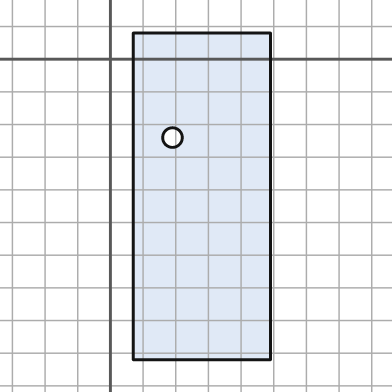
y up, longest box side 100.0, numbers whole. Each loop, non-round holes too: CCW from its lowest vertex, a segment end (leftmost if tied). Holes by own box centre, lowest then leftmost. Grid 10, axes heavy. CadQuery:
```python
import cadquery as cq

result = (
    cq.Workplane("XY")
    .moveTo(7.0, -92.0)
    .lineTo(49.0, -92.0)
    .lineTo(49.0, 8.0)
    .lineTo(7.0, 8.0)
    .close()
    .moveTo(19.0, -24.0)
    .circle(3.0)
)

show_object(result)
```